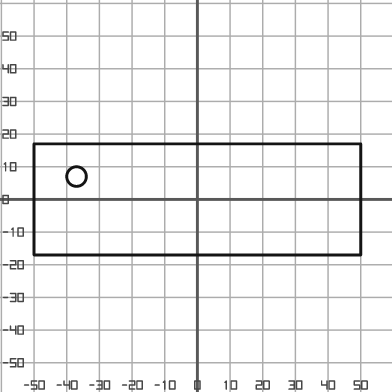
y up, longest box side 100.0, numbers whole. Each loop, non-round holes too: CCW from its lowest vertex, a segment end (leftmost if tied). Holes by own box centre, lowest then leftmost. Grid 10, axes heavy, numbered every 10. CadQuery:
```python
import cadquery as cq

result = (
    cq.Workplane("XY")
    .moveTo(-50.0, -17.0)
    .lineTo(50.0, -17.0)
    .lineTo(50.0, 17.0)
    .lineTo(-50.0, 17.0)
    .close()
    .moveTo(-37.0, 7.0)
    .circle(3.0)
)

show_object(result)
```